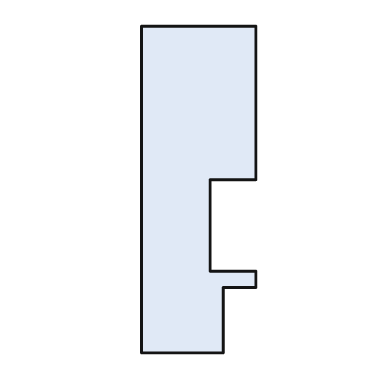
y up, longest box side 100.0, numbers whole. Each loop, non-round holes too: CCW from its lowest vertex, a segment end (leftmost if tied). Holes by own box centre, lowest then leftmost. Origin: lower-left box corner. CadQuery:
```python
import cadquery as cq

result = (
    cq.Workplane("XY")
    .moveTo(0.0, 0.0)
    .lineTo(25.0, 0.0)
    .lineTo(25.0, 20.0)
    .lineTo(35.0, 20.0)
    .lineTo(35.0, 25.0)
    .lineTo(21.0, 25.0)
    .lineTo(21.0, 53.0)
    .lineTo(35.0, 53.0)
    .lineTo(35.0, 100.0)
    .lineTo(0.0, 100.0)
    .close()
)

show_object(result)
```